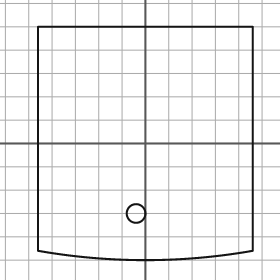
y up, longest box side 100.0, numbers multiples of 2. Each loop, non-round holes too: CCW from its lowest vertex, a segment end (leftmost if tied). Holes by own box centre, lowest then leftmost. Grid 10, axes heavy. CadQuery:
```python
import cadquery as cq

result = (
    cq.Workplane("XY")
    .moveTo(-46.0, -46.0)
    .threePointArc((0.0, -50.0), (46.0, -46.0))
    .lineTo(46.0, 50.0)
    .lineTo(-46.0, 50.0)
    .close()
    .moveTo(-4.0, -30.0)
    .circle(4.0)
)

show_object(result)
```